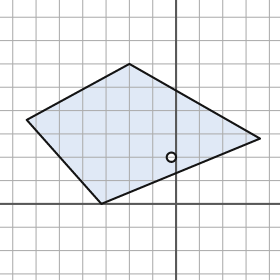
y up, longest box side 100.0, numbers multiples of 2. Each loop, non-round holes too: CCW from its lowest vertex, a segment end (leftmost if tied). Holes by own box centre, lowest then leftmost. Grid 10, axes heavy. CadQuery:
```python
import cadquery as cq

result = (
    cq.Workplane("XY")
    .moveTo(-32.0, 0.0)
    .lineTo(36.0, 28.0)
    .lineTo(-20.0, 60.0)
    .lineTo(-64.0, 36.0)
    .close()
    .moveTo(-2.0, 20.0)
    .circle(2.0)
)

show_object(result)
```